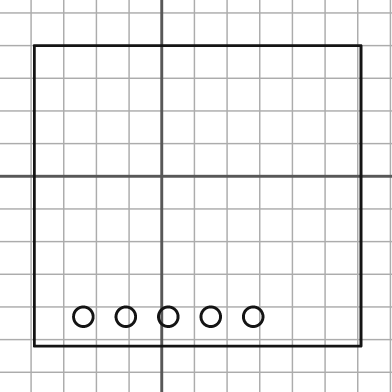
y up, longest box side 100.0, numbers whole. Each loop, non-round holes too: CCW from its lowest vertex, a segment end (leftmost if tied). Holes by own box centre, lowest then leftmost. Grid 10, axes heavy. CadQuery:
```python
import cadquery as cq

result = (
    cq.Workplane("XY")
    .moveTo(-39.0, -52.0)
    .lineTo(61.0, -52.0)
    .lineTo(61.0, 40.0)
    .lineTo(-39.0, 40.0)
    .close()
    .moveTo(-24.0, -43.0)
    .circle(3.0)
    .moveTo(-11.0, -43.0)
    .circle(3.0)
    .moveTo(2.0, -43.0)
    .circle(3.0)
    .moveTo(15.0, -43.0)
    .circle(3.0)
    .moveTo(28.0, -43.0)
    .circle(3.0)
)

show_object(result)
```